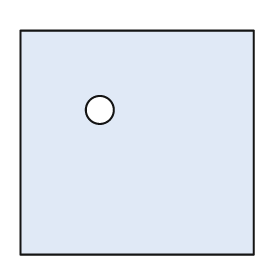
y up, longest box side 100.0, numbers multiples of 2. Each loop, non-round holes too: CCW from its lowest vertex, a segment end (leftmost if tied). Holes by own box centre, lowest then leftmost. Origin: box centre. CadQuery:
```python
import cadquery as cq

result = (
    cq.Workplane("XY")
    .moveTo(-50.0, -48.0)
    .lineTo(50.0, -48.0)
    .lineTo(50.0, 48.0)
    .lineTo(-50.0, 48.0)
    .close()
    .moveTo(-16.0, 14.0)
    .circle(6.0)
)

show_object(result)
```